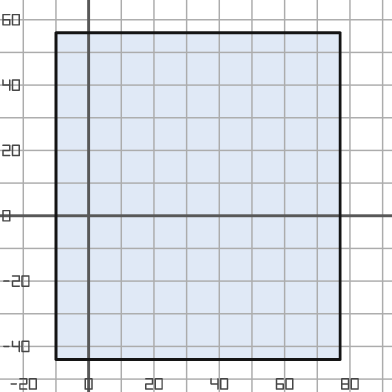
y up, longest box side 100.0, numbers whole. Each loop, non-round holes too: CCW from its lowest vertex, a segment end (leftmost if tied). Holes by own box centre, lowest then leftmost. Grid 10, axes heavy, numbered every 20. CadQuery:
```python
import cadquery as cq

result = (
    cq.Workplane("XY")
    .moveTo(-10.0, -44.0)
    .lineTo(77.0, -44.0)
    .lineTo(77.0, 56.0)
    .lineTo(-10.0, 56.0)
    .close()
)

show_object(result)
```